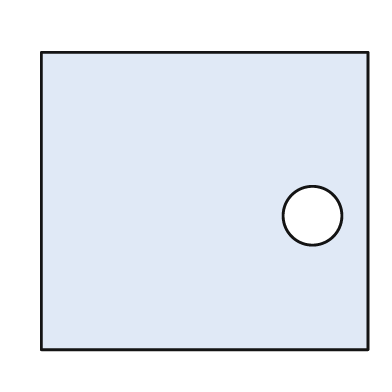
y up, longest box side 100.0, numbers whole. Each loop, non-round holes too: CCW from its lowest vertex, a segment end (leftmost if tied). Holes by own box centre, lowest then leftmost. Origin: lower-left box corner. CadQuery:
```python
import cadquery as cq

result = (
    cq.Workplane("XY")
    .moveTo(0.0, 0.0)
    .lineTo(100.0, 0.0)
    .lineTo(100.0, 91.0)
    .lineTo(0.0, 91.0)
    .close()
    .moveTo(83.0, 41.0)
    .circle(9.0)
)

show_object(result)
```